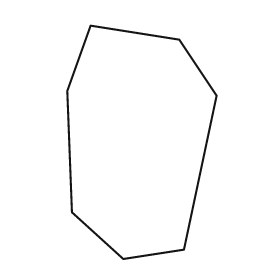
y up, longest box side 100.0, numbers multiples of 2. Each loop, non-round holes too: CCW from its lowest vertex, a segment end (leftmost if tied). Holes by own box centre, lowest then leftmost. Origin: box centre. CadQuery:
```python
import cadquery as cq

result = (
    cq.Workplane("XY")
    .moveTo(-8.0, -50.0)
    .lineTo(18.0, -46.0)
    .lineTo(32.0, 20.0)
    .lineTo(16.0, 44.0)
    .lineTo(-22.0, 50.0)
    .lineTo(-32.0, 22.0)
    .lineTo(-30.0, -30.0)
    .close()
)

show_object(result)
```